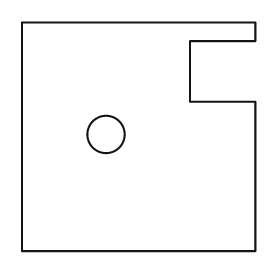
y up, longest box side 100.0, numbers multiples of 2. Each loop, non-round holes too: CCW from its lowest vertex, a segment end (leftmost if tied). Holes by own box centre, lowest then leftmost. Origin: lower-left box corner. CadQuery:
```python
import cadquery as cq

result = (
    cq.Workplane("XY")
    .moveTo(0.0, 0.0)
    .lineTo(100.0, 0.0)
    .lineTo(100.0, 64.0)
    .lineTo(72.0, 64.0)
    .lineTo(72.0, 90.0)
    .lineTo(100.0, 90.0)
    .lineTo(100.0, 98.0)
    .lineTo(0.0, 98.0)
    .close()
    .moveTo(36.0, 50.0)
    .circle(8.0)
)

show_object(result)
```